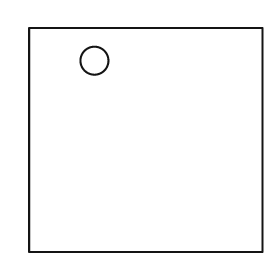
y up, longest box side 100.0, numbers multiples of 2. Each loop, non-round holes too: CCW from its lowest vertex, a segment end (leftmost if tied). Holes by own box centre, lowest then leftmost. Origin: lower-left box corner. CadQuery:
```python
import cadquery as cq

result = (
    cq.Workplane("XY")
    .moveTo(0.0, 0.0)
    .lineTo(100.0, 0.0)
    .lineTo(100.0, 96.0)
    .lineTo(0.0, 96.0)
    .close()
    .moveTo(28.0, 82.0)
    .circle(6.0)
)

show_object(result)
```